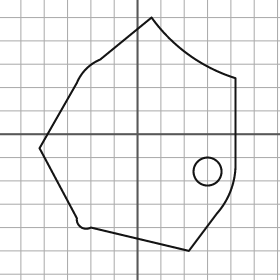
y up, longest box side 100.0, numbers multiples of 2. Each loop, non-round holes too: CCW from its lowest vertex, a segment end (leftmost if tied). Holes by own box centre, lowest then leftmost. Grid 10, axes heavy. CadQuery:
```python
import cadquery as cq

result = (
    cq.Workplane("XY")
    .moveTo(22.0, -50.0)
    .lineTo(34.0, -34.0)
    .threePointArc((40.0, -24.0), (42.0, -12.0))
    .lineTo(42.0, 24.0)
    .threePointArc((22.0, 34.0), (6.0, 50.0))
    .lineTo(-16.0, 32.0)
    .threePointArc((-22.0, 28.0), (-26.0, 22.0))
    .lineTo(-42.0, -6.0)
    .lineTo(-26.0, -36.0)
    .threePointArc((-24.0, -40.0), (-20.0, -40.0))
    .close()
    .moveTo(30.0, -16.0)
    .circle(6.0)
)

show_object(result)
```